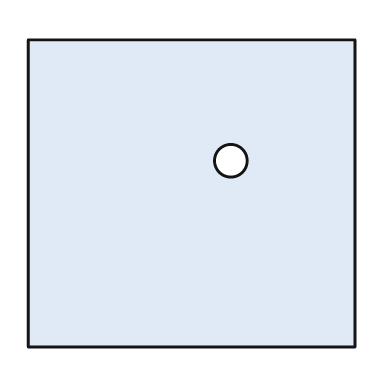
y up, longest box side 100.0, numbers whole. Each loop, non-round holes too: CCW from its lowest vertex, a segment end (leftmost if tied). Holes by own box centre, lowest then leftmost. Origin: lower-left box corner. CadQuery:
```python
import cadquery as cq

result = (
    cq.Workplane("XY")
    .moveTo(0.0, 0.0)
    .lineTo(100.0, 0.0)
    .lineTo(100.0, 94.0)
    .lineTo(0.0, 94.0)
    .close()
    .moveTo(62.0, 57.0)
    .circle(5.0)
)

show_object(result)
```